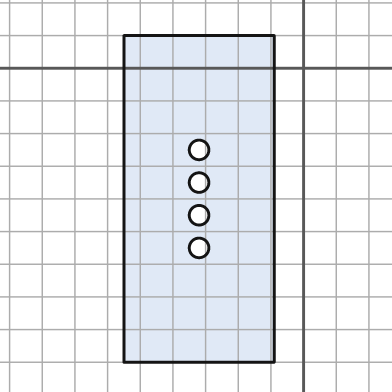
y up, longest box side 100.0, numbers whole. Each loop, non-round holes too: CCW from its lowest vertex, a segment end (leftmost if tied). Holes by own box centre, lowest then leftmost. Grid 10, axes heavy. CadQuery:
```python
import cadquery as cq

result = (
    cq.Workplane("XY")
    .moveTo(-55.0, -90.0)
    .lineTo(-9.0, -90.0)
    .lineTo(-9.0, 10.0)
    .lineTo(-55.0, 10.0)
    .close()
    .moveTo(-32.0, -55.0)
    .circle(3.0)
    .moveTo(-32.0, -45.0)
    .circle(3.0)
    .moveTo(-32.0, -35.0)
    .circle(3.0)
    .moveTo(-32.0, -25.0)
    .circle(3.0)
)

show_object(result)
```